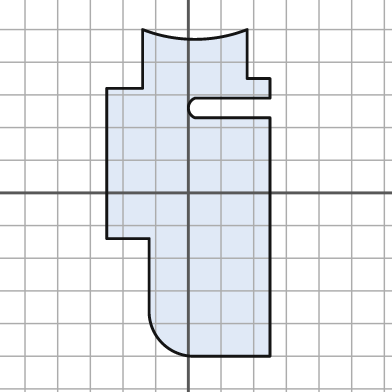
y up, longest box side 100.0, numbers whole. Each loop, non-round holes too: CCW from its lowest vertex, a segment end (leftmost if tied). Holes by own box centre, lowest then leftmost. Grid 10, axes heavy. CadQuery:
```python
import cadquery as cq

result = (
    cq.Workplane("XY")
    .moveTo(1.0, -50.0)
    .lineTo(25.0, -50.0)
    .lineTo(25.0, 23.0)
    .lineTo(2.0, 23.0)
    .threePointArc((0.0, 26.0), (2.0, 29.0))
    .lineTo(25.0, 29.0)
    .lineTo(25.0, 35.0)
    .lineTo(18.0, 35.0)
    .lineTo(18.0, 50.0)
    .threePointArc((2.0, 47.0), (-14.0, 50.0))
    .lineTo(-14.0, 32.0)
    .lineTo(-25.0, 32.0)
    .lineTo(-25.0, -14.0)
    .lineTo(-12.0, -14.0)
    .lineTo(-12.0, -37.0)
    .threePointArc((-8.0, -46.0), (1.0, -50.0))
    .close()
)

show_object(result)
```